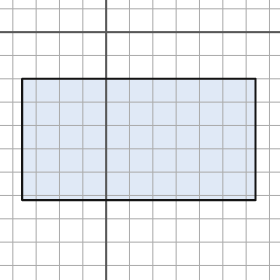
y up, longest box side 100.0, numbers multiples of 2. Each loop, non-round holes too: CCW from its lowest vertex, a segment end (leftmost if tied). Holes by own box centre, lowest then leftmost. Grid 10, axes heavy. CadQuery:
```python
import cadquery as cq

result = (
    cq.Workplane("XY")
    .moveTo(-36.0, -72.0)
    .lineTo(64.0, -72.0)
    .lineTo(64.0, -20.0)
    .lineTo(-36.0, -20.0)
    .close()
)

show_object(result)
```